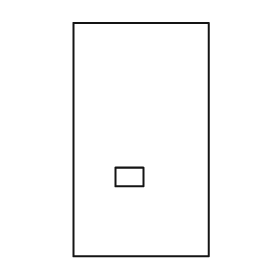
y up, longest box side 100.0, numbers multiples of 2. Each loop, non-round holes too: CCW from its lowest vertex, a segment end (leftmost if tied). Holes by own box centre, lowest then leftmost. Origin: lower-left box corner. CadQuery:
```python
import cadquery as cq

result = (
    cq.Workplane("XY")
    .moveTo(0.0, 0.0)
    .lineTo(58.0, 0.0)
    .lineTo(58.0, 100.0)
    .lineTo(0.0, 100.0)
    .close()
    .moveTo(18.0, 30.0)
    .lineTo(30.0, 30.0)
    .lineTo(30.0, 38.0)
    .lineTo(18.0, 38.0)
    .close()
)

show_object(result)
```